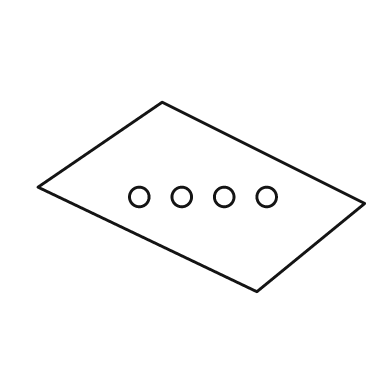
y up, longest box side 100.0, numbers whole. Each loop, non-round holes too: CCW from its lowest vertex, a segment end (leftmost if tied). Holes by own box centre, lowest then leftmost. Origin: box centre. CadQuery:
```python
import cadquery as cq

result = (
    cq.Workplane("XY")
    .moveTo(17.0, -29.0)
    .lineTo(50.0, -2.0)
    .lineTo(-12.0, 29.0)
    .lineTo(-50.0, 3.0)
    .close()
    .moveTo(-19.0, 0.0)
    .circle(3.0)
    .moveTo(-6.0, 0.0)
    .circle(3.0)
    .moveTo(7.0, 0.0)
    .circle(3.0)
    .moveTo(20.0, 0.0)
    .circle(3.0)
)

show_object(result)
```